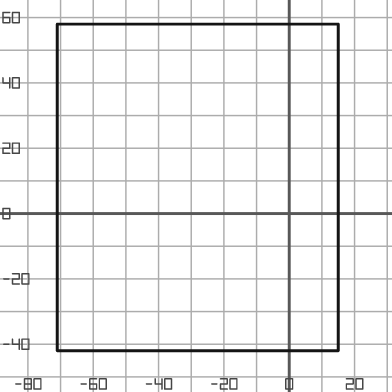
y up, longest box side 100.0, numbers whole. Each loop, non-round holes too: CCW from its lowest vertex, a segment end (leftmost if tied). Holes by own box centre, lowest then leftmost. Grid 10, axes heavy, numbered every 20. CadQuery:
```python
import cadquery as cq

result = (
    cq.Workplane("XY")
    .moveTo(-71.0, -42.0)
    .lineTo(15.0, -42.0)
    .lineTo(15.0, 58.0)
    .lineTo(-71.0, 58.0)
    .close()
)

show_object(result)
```